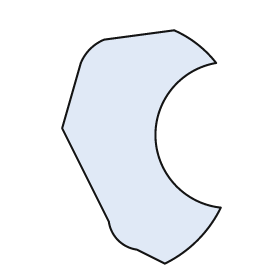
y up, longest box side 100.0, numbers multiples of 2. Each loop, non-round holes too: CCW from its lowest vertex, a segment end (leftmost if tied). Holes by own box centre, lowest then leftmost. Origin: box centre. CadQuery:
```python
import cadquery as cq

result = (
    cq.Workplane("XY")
    .moveTo(10.0, -50.0)
    .threePointArc((24.0, -40.0), (34.0, -26.0))
    .threePointArc((6.0, 4.0), (32.0, 36.0))
    .threePointArc((24.0, 44.0), (14.0, 50.0))
    .lineTo(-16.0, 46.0)
    .threePointArc((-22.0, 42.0), (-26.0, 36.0))
    .lineTo(-34.0, 8.0)
    .lineTo(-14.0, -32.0)
    .threePointArc((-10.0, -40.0), (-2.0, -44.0))
    .close()
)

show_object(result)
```